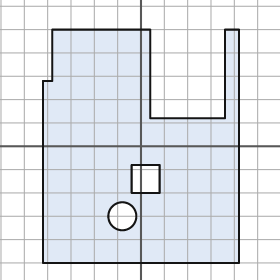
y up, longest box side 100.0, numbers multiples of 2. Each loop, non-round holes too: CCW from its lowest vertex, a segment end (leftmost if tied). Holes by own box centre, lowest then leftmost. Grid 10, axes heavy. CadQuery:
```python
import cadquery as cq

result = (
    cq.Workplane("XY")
    .moveTo(-42.0, -50.0)
    .lineTo(42.0, -50.0)
    .lineTo(42.0, 50.0)
    .lineTo(36.0, 50.0)
    .lineTo(36.0, 12.0)
    .lineTo(4.0, 12.0)
    .lineTo(4.0, 50.0)
    .lineTo(-38.0, 50.0)
    .lineTo(-38.0, 28.0)
    .lineTo(-42.0, 28.0)
    .close()
    .moveTo(-8.0, -30.0)
    .circle(6.0)
    .moveTo(-4.0, -20.0)
    .lineTo(8.0, -20.0)
    .lineTo(8.0, -8.0)
    .lineTo(-4.0, -8.0)
    .close()
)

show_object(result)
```